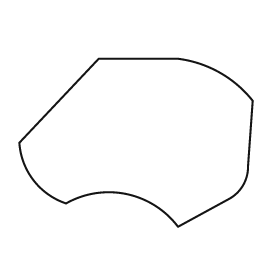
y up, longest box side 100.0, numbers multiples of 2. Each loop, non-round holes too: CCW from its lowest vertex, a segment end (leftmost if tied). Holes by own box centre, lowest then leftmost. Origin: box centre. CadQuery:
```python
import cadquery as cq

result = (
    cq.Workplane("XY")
    .moveTo(18.0, -36.0)
    .lineTo(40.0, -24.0)
    .threePointArc((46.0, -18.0), (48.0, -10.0))
    .lineTo(50.0, 18.0)
    .threePointArc((36.0, 30.0), (18.0, 36.0))
    .lineTo(-16.0, 36.0)
    .lineTo(-50.0, 0.0)
    .threePointArc((-44.0, -16.0), (-30.0, -26.0))
    .threePointArc((-4.0, -22.0), (18.0, -36.0))
    .close()
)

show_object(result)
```